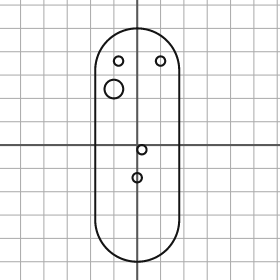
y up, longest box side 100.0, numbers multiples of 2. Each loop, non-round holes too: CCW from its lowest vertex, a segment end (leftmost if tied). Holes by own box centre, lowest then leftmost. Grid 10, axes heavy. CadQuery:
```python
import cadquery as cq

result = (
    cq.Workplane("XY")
    .moveTo(-18.0, -32.0)
    .threePointArc((0.0, -50.0), (18.0, -32.0))
    .lineTo(18.0, 32.0)
    .threePointArc((0.0, 50.0), (-18.0, 32.0))
    .close()
    .moveTo(0.0, -14.0)
    .circle(2.0)
    .moveTo(2.0, -2.0)
    .circle(2.0)
    .moveTo(-10.0, 24.0)
    .circle(4.0)
    .moveTo(-8.0, 36.0)
    .circle(2.0)
    .moveTo(10.0, 36.0)
    .circle(2.0)
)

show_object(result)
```